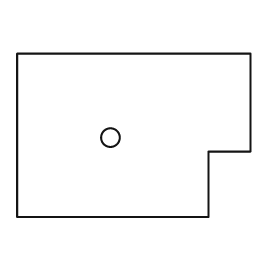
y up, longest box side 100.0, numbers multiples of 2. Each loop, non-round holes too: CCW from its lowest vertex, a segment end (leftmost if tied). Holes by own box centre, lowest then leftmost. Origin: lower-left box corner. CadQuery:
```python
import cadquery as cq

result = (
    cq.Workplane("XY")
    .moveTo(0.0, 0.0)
    .lineTo(82.0, 0.0)
    .lineTo(82.0, 28.0)
    .lineTo(100.0, 28.0)
    .lineTo(100.0, 70.0)
    .lineTo(0.0, 70.0)
    .close()
    .moveTo(40.0, 34.0)
    .circle(4.0)
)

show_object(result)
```